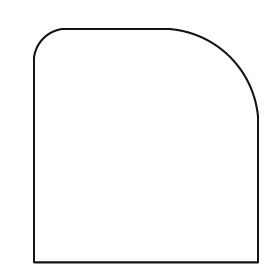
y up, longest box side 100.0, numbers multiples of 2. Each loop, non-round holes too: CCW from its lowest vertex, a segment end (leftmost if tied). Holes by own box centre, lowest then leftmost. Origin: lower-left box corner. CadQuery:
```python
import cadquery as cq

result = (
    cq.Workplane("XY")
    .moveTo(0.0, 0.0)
    .lineTo(96.0, 0.0)
    .lineTo(96.0, 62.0)
    .threePointArc((84.0, 88.0), (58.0, 100.0))
    .lineTo(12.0, 100.0)
    .threePointArc((4.0, 96.0), (0.0, 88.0))
    .close()
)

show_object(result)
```